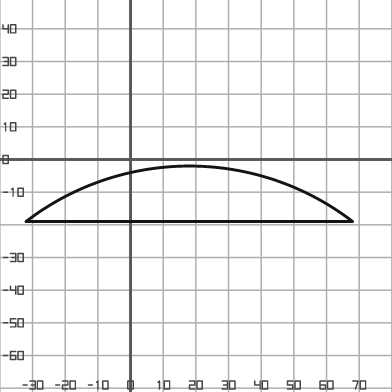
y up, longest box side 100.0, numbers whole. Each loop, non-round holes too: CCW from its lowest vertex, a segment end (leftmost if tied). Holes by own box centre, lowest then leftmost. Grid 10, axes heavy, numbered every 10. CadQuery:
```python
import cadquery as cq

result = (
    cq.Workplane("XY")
    .moveTo(-32.0, -19.0)
    .lineTo(68.0, -19.0)
    .threePointArc((18.0, -2.0), (-32.0, -19.0))
    .close()
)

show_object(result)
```